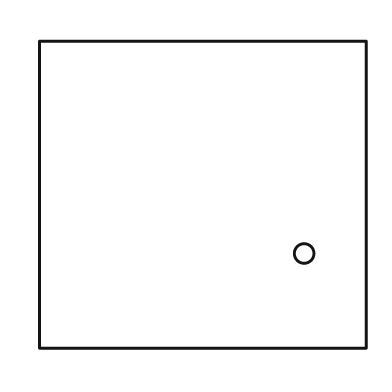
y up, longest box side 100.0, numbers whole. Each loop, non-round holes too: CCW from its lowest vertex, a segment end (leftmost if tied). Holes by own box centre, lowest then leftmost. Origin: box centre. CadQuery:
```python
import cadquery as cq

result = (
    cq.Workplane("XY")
    .moveTo(-50.0, -47.0)
    .lineTo(50.0, -47.0)
    .lineTo(50.0, 47.0)
    .lineTo(-50.0, 47.0)
    .close()
    .moveTo(31.0, -18.0)
    .circle(3.0)
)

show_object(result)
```